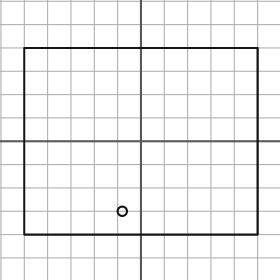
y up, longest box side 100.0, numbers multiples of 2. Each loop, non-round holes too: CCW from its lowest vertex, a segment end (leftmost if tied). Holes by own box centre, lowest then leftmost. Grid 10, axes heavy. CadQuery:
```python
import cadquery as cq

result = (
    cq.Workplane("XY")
    .moveTo(-50.0, -40.0)
    .lineTo(50.0, -40.0)
    .lineTo(50.0, 40.0)
    .lineTo(-50.0, 40.0)
    .close()
    .moveTo(-8.0, -30.0)
    .circle(2.0)
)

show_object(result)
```